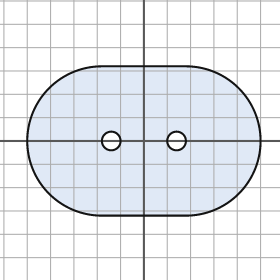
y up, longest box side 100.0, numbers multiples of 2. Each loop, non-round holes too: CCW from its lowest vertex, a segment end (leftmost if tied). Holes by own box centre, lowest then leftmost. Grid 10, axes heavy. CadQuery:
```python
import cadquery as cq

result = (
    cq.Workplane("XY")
    .moveTo(-18.0, -32.0)
    .lineTo(18.0, -32.0)
    .threePointArc((50.0, 0.0), (18.0, 32.0))
    .lineTo(-18.0, 32.0)
    .threePointArc((-50.0, 0.0), (-18.0, -32.0))
    .close()
    .moveTo(-14.0, 0.0)
    .circle(4.0)
    .moveTo(14.0, 0.0)
    .circle(4.0)
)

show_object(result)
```